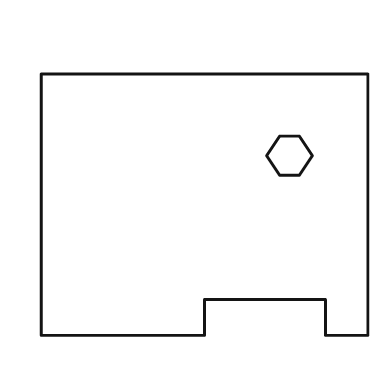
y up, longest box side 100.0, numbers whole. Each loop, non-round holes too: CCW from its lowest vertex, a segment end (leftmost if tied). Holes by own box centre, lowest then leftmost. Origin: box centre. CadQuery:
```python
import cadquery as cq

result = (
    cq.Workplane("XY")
    .moveTo(-50.0, -40.0)
    .lineTo(0.0, -40.0)
    .lineTo(0.0, -29.0)
    .lineTo(37.0, -29.0)
    .lineTo(37.0, -40.0)
    .lineTo(50.0, -40.0)
    .lineTo(50.0, 40.0)
    .lineTo(-50.0, 40.0)
    .close()
    .moveTo(23.0, 9.0)
    .lineTo(29.0, 9.0)
    .lineTo(33.0, 15.0)
    .lineTo(29.0, 21.0)
    .lineTo(23.0, 21.0)
    .lineTo(19.0, 15.0)
    .close()
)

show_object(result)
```